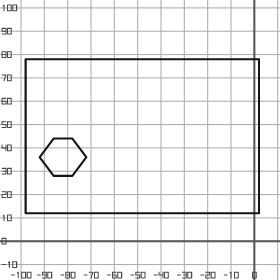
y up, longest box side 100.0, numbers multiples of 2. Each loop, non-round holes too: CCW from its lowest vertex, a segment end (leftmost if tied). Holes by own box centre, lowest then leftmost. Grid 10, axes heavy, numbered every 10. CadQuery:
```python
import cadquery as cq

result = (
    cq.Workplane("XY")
    .moveTo(-98.0, 12.0)
    .lineTo(2.0, 12.0)
    .lineTo(2.0, 78.0)
    .lineTo(-98.0, 78.0)
    .close()
    .moveTo(-86.0, 28.0)
    .lineTo(-78.0, 28.0)
    .lineTo(-72.0, 36.0)
    .lineTo(-78.0, 44.0)
    .lineTo(-86.0, 44.0)
    .lineTo(-92.0, 36.0)
    .close()
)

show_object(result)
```